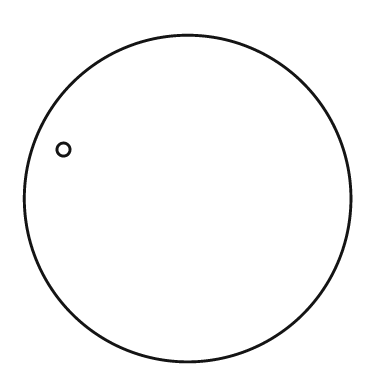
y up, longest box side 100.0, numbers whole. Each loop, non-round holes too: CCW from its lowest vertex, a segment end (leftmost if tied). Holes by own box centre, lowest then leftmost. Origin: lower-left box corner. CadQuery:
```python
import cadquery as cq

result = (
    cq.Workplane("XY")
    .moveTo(50.0, 50.0)
    .circle(50.0)
    .moveTo(12.0, 65.0)
    .circle(2.0)
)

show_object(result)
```